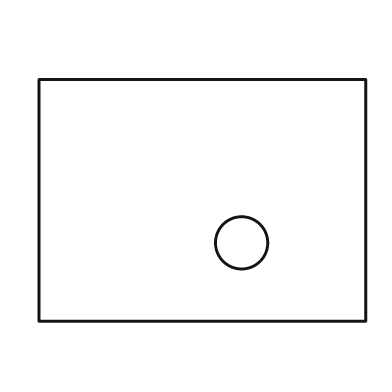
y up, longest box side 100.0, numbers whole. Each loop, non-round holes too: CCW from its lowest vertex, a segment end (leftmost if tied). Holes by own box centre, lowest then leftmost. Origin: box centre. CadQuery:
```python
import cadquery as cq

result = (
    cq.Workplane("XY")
    .moveTo(-50.0, -37.0)
    .lineTo(50.0, -37.0)
    .lineTo(50.0, 37.0)
    .lineTo(-50.0, 37.0)
    .close()
    .moveTo(12.0, -13.0)
    .circle(8.0)
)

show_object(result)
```